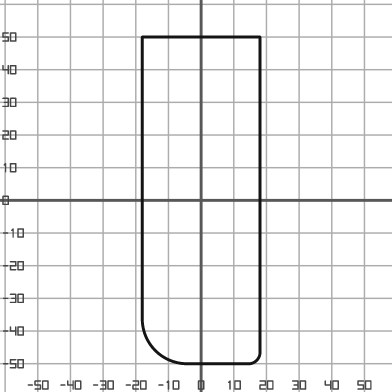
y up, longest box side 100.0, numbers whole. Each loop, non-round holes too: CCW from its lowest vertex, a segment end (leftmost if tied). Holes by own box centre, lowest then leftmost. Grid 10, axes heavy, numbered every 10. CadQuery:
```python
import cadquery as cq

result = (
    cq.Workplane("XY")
    .moveTo(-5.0, -50.0)
    .lineTo(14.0, -50.0)
    .threePointArc((17.0, -49.0), (18.0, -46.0))
    .lineTo(18.0, 50.0)
    .lineTo(-18.0, 50.0)
    .lineTo(-18.0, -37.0)
    .threePointArc((-14.0, -46.0), (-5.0, -50.0))
    .close()
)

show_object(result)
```